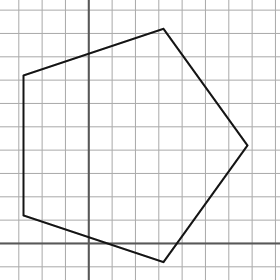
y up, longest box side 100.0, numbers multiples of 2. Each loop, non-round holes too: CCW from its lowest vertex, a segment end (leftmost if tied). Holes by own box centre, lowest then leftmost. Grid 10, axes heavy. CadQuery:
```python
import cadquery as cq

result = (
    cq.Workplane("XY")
    .moveTo(32.0, -8.0)
    .lineTo(68.0, 42.0)
    .lineTo(32.0, 92.0)
    .lineTo(-28.0, 72.0)
    .lineTo(-28.0, 12.0)
    .close()
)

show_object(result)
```